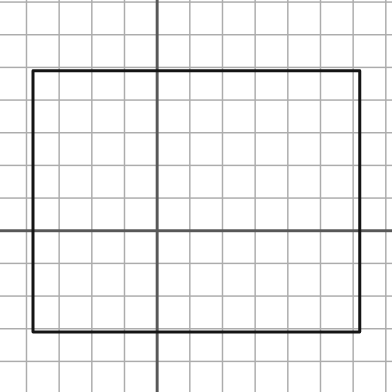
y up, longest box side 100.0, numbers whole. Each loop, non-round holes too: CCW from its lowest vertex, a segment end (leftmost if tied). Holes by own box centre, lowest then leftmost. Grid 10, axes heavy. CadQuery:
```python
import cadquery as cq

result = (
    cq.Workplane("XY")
    .moveTo(-38.0, -31.0)
    .lineTo(62.0, -31.0)
    .lineTo(62.0, 49.0)
    .lineTo(-38.0, 49.0)
    .close()
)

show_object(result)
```